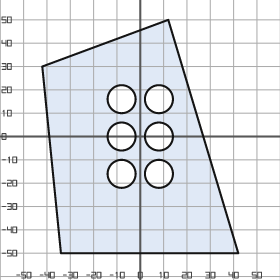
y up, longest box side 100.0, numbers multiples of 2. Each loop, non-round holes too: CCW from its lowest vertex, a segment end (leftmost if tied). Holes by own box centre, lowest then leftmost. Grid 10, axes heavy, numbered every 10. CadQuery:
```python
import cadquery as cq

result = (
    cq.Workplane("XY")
    .moveTo(-34.0, -50.0)
    .lineTo(42.0, -50.0)
    .lineTo(12.0, 50.0)
    .lineTo(-42.0, 30.0)
    .close()
    .moveTo(-8.0, -16.0)
    .circle(6.0)
    .moveTo(8.0, -16.0)
    .circle(6.0)
    .moveTo(-8.0, 0.0)
    .circle(6.0)
    .moveTo(8.0, 0.0)
    .circle(6.0)
    .moveTo(-8.0, 16.0)
    .circle(6.0)
    .moveTo(8.0, 16.0)
    .circle(6.0)
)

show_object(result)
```